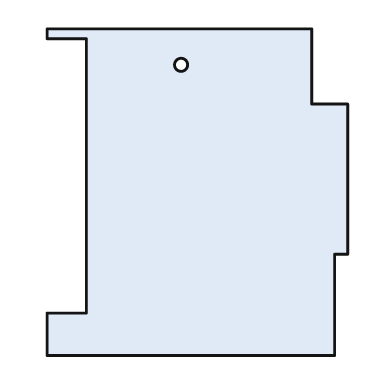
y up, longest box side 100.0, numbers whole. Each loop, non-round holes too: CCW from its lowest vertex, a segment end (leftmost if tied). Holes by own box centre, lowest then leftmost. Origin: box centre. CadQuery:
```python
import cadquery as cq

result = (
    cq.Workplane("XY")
    .moveTo(-46.0, -50.0)
    .lineTo(42.0, -50.0)
    .lineTo(42.0, -19.0)
    .lineTo(46.0, -19.0)
    .lineTo(46.0, 27.0)
    .lineTo(35.0, 27.0)
    .lineTo(35.0, 50.0)
    .lineTo(-46.0, 50.0)
    .lineTo(-46.0, 47.0)
    .lineTo(-34.0, 47.0)
    .lineTo(-34.0, -37.0)
    .lineTo(-46.0, -37.0)
    .close()
    .moveTo(-5.0, 39.0)
    .circle(2.0)
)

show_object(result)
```